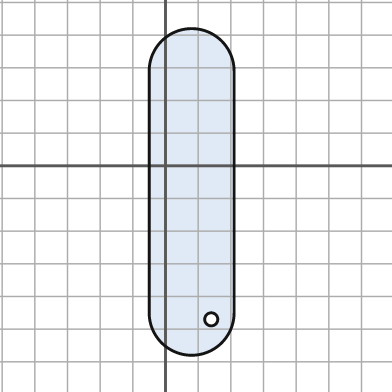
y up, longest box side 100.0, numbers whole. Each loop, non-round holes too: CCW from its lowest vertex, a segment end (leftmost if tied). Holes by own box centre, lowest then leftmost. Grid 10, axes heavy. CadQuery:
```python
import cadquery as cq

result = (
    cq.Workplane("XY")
    .moveTo(-5.0, -45.0)
    .threePointArc((8.0, -58.0), (21.0, -45.0))
    .lineTo(21.0, 29.0)
    .threePointArc((8.0, 42.0), (-5.0, 29.0))
    .close()
    .moveTo(14.0, -47.0)
    .circle(2.0)
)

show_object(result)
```